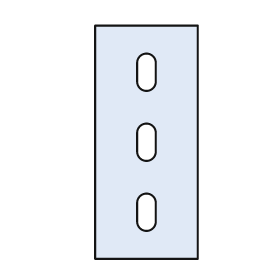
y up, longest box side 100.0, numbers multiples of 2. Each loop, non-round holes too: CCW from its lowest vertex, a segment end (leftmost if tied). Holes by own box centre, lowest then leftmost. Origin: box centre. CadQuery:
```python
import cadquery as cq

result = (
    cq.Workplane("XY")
    .moveTo(-22.0, -50.0)
    .lineTo(22.0, -50.0)
    .lineTo(22.0, 50.0)
    .lineTo(-22.0, 50.0)
    .close()
    .moveTo(-4.0, -34.0)
    .threePointArc((0.0, -38.0), (4.0, -34.0))
    .lineTo(4.0, -26.0)
    .threePointArc((0.0, -22.0), (-4.0, -26.0))
    .close()
    .moveTo(-4.0, -4.0)
    .threePointArc((0.0, -8.0), (4.0, -4.0))
    .lineTo(4.0, 4.0)
    .threePointArc((0.0, 8.0), (-4.0, 4.0))
    .close()
    .moveTo(-4.0, 26.0)
    .threePointArc((0.0, 22.0), (4.0, 26.0))
    .lineTo(4.0, 34.0)
    .threePointArc((0.0, 38.0), (-4.0, 34.0))
    .close()
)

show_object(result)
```